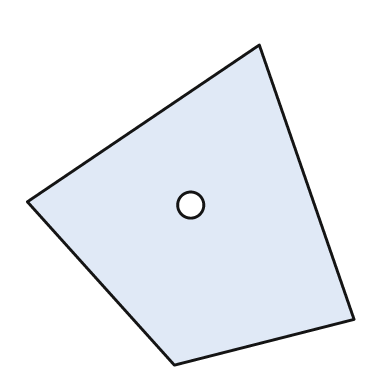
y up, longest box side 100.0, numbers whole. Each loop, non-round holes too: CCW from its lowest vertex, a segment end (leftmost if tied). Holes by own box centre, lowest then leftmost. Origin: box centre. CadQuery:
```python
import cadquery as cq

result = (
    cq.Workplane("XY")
    .moveTo(-5.0, -49.0)
    .lineTo(50.0, -35.0)
    .lineTo(21.0, 49.0)
    .lineTo(-50.0, 1.0)
    .close()
    .moveTo(0.0, 0.0)
    .circle(4.0)
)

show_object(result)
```